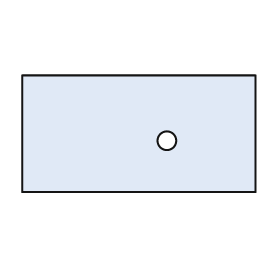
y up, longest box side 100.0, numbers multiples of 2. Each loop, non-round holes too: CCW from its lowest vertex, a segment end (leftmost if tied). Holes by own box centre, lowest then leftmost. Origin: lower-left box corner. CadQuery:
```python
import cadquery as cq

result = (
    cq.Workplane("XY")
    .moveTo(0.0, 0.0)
    .lineTo(100.0, 0.0)
    .lineTo(100.0, 50.0)
    .lineTo(0.0, 50.0)
    .close()
    .moveTo(62.0, 22.0)
    .circle(4.0)
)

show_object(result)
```